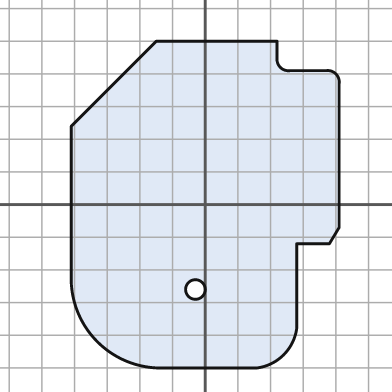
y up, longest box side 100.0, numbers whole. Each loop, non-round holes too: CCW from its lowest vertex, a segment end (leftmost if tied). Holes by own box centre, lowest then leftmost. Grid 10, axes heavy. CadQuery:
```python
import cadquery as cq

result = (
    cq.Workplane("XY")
    .moveTo(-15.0, -50.0)
    .lineTo(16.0, -50.0)
    .threePointArc((24.0, -46.0), (28.0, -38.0))
    .lineTo(28.0, -12.0)
    .lineTo(38.0, -12.0)
    .lineTo(41.0, -7.0)
    .lineTo(41.0, 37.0)
    .threePointArc((40.0, 40.0), (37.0, 41.0))
    .lineTo(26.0, 41.0)
    .threePointArc((23.0, 42.0), (22.0, 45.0))
    .lineTo(22.0, 50.0)
    .lineTo(-15.0, 50.0)
    .lineTo(-41.0, 24.0)
    .lineTo(-41.0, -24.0)
    .threePointArc((-33.0, -42.0), (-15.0, -50.0))
    .close()
    .moveTo(-3.0, -26.0)
    .circle(3.0)
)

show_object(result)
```